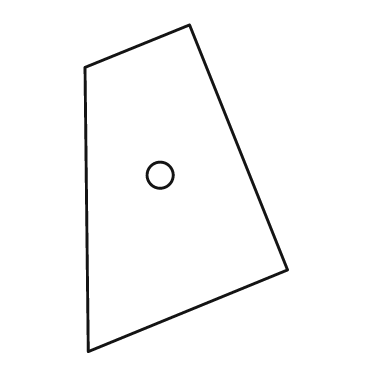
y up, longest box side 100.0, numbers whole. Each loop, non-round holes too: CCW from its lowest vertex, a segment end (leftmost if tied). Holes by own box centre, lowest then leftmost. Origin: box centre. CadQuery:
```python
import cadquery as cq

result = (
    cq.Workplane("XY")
    .moveTo(-30.0, -50.0)
    .lineTo(31.0, -25.0)
    .lineTo(1.0, 50.0)
    .lineTo(-31.0, 37.0)
    .close()
    .moveTo(-8.0, 4.0)
    .circle(4.0)
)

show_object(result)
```